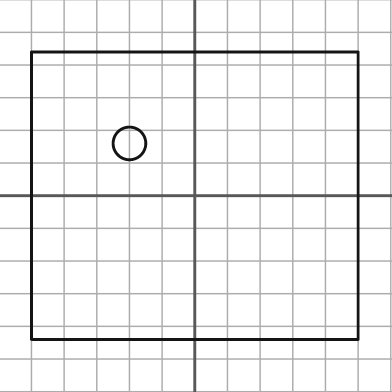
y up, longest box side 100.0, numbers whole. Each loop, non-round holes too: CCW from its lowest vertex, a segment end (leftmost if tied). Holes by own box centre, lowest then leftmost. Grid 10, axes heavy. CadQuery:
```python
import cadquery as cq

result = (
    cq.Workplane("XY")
    .moveTo(-50.0, -44.0)
    .lineTo(50.0, -44.0)
    .lineTo(50.0, 44.0)
    .lineTo(-50.0, 44.0)
    .close()
    .moveTo(-20.0, 16.0)
    .circle(5.0)
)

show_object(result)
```